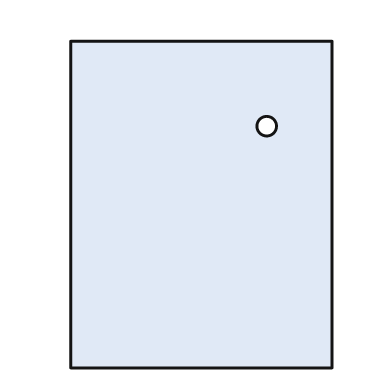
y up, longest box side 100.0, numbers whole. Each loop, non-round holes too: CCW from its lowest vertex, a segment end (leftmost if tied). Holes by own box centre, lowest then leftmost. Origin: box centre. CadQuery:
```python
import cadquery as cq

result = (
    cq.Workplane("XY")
    .moveTo(-40.0, -50.0)
    .lineTo(40.0, -50.0)
    .lineTo(40.0, 50.0)
    .lineTo(-40.0, 50.0)
    .close()
    .moveTo(20.0, 24.0)
    .circle(3.0)
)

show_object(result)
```